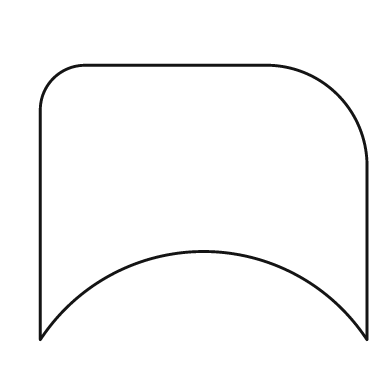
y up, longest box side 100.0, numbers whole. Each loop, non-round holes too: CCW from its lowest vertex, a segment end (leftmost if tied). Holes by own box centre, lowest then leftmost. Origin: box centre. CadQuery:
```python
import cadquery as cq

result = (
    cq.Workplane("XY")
    .moveTo(-50.0, -42.0)
    .threePointArc((0.0, -15.0), (50.0, -42.0))
    .lineTo(50.0, 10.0)
    .threePointArc((41.0, 33.0), (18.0, 42.0))
    .lineTo(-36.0, 42.0)
    .threePointArc((-46.0, 38.0), (-50.0, 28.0))
    .close()
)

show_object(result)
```